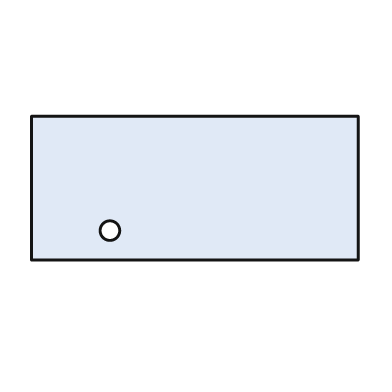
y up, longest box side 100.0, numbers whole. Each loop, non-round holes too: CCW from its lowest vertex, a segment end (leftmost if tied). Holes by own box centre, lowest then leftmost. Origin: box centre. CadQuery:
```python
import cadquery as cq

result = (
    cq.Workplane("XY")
    .moveTo(-50.0, -22.0)
    .lineTo(50.0, -22.0)
    .lineTo(50.0, 22.0)
    .lineTo(-50.0, 22.0)
    .close()
    .moveTo(-26.0, -13.0)
    .circle(3.0)
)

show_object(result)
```